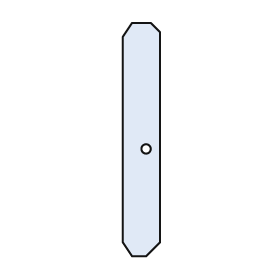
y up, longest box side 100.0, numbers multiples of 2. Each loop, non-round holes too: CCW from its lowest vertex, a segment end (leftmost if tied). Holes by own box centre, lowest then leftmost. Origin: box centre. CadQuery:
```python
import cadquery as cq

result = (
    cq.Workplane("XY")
    .moveTo(-4.0, -50.0)
    .lineTo(2.0, -50.0)
    .lineTo(8.0, -44.0)
    .lineTo(8.0, 46.0)
    .lineTo(4.0, 50.0)
    .lineTo(-4.0, 50.0)
    .lineTo(-8.0, 44.0)
    .lineTo(-8.0, -44.0)
    .close()
    .moveTo(2.0, -4.0)
    .circle(2.0)
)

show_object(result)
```